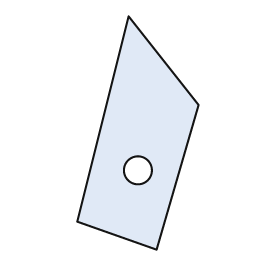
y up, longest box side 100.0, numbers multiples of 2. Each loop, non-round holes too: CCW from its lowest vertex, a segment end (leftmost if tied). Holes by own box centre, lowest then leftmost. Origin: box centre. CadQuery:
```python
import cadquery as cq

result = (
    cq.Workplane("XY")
    .moveTo(8.0, -50.0)
    .lineTo(26.0, 12.0)
    .lineTo(-4.0, 50.0)
    .lineTo(-26.0, -38.0)
    .close()
    .moveTo(0.0, -16.0)
    .circle(6.0)
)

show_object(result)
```